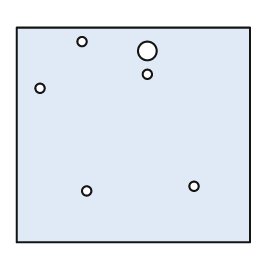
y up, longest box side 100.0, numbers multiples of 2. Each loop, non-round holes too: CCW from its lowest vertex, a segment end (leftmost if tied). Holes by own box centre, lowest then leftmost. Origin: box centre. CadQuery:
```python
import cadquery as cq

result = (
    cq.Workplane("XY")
    .moveTo(-50.0, -46.0)
    .lineTo(50.0, -46.0)
    .lineTo(50.0, 46.0)
    .lineTo(-50.0, 46.0)
    .close()
    .moveTo(-20.0, -24.0)
    .circle(2.0)
    .moveTo(26.0, -22.0)
    .circle(2.0)
    .moveTo(-40.0, 20.0)
    .circle(2.0)
    .moveTo(6.0, 26.0)
    .circle(2.0)
    .moveTo(6.0, 36.0)
    .circle(4.0)
    .moveTo(-22.0, 40.0)
    .circle(2.0)
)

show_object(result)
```